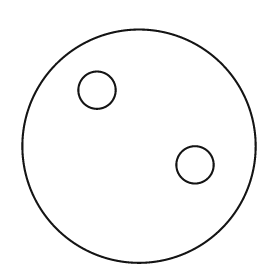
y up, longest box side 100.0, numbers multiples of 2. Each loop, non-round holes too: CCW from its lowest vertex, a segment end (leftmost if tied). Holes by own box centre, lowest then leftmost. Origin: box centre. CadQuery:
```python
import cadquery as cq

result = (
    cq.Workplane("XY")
    .moveTo(0.0, 0.0)
    .circle(50.0)
    .moveTo(24.0, -8.0)
    .circle(8.0)
    .moveTo(-18.0, 24.0)
    .circle(8.0)
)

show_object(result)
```